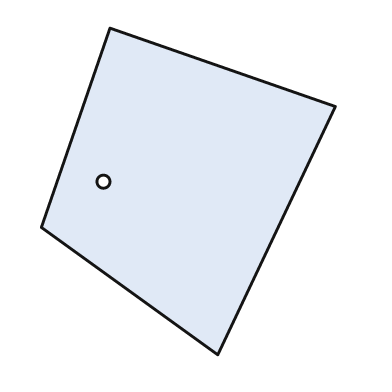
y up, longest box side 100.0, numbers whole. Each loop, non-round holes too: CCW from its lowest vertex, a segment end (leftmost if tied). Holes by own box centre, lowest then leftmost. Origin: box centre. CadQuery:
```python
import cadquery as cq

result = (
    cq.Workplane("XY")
    .moveTo(9.0, -50.0)
    .lineTo(45.0, 26.0)
    .lineTo(-24.0, 50.0)
    .lineTo(-45.0, -11.0)
    .close()
    .moveTo(-26.0, 3.0)
    .circle(2.0)
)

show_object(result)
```